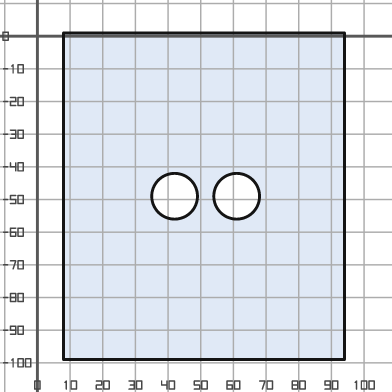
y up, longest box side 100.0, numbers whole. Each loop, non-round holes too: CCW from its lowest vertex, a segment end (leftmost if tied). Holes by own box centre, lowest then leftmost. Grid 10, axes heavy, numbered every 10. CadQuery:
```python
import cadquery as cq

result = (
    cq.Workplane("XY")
    .moveTo(8.0, -99.0)
    .lineTo(94.0, -99.0)
    .lineTo(94.0, 1.0)
    .lineTo(8.0, 1.0)
    .close()
    .moveTo(42.0, -49.0)
    .circle(7.0)
    .moveTo(61.0, -49.0)
    .circle(7.0)
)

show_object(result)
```